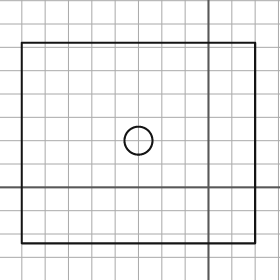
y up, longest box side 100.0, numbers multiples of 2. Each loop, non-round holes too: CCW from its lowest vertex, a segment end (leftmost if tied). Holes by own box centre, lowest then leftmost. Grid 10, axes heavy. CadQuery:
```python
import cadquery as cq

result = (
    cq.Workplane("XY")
    .moveTo(-80.0, -24.0)
    .lineTo(20.0, -24.0)
    .lineTo(20.0, 62.0)
    .lineTo(-80.0, 62.0)
    .close()
    .moveTo(-30.0, 20.0)
    .circle(6.0)
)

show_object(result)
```